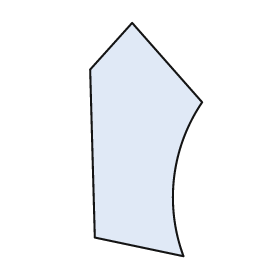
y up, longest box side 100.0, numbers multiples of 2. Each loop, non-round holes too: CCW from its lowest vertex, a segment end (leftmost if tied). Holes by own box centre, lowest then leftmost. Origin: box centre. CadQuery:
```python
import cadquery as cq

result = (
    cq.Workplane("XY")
    .moveTo(16.0, -50.0)
    .threePointArc((12.0, -16.0), (24.0, 16.0))
    .lineTo(-6.0, 50.0)
    .lineTo(-24.0, 30.0)
    .lineTo(-22.0, -42.0)
    .close()
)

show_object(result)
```